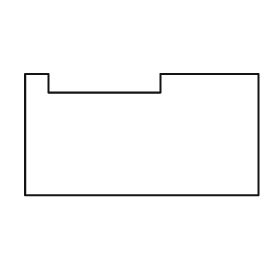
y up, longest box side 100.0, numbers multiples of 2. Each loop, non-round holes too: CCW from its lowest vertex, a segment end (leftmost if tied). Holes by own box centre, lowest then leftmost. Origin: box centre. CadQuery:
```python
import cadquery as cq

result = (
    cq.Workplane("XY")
    .moveTo(-50.0, -26.0)
    .lineTo(50.0, -26.0)
    .lineTo(50.0, 26.0)
    .lineTo(8.0, 26.0)
    .lineTo(8.0, 18.0)
    .lineTo(-40.0, 18.0)
    .lineTo(-40.0, 26.0)
    .lineTo(-50.0, 26.0)
    .close()
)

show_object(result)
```